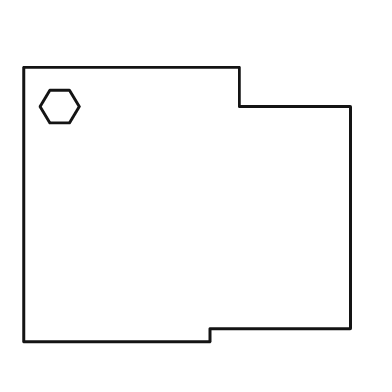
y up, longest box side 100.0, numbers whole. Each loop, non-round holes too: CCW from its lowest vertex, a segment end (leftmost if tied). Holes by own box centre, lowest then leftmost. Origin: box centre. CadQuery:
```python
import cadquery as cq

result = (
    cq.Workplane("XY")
    .moveTo(-50.0, -42.0)
    .lineTo(7.0, -42.0)
    .lineTo(7.0, -38.0)
    .lineTo(50.0, -38.0)
    .lineTo(50.0, 30.0)
    .lineTo(16.0, 30.0)
    .lineTo(16.0, 42.0)
    .lineTo(-50.0, 42.0)
    .close()
    .moveTo(-42.0, 25.0)
    .lineTo(-36.0, 25.0)
    .lineTo(-33.0, 30.0)
    .lineTo(-36.0, 35.0)
    .lineTo(-42.0, 35.0)
    .lineTo(-45.0, 30.0)
    .close()
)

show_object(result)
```